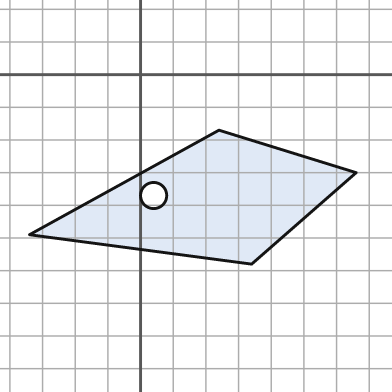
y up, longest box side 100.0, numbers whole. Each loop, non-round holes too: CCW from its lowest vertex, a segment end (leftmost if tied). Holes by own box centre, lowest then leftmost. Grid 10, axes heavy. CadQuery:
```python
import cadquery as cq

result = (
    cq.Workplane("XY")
    .moveTo(34.0, -58.0)
    .lineTo(66.0, -30.0)
    .lineTo(24.0, -17.0)
    .lineTo(-34.0, -49.0)
    .close()
    .moveTo(4.0, -37.0)
    .circle(4.0)
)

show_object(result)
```